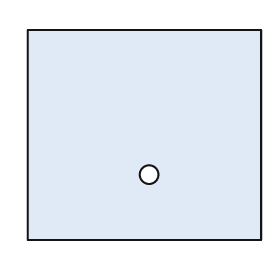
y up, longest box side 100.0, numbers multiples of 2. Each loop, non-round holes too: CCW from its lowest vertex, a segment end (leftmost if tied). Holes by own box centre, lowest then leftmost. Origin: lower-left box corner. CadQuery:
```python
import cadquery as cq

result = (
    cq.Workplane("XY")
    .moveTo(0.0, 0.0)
    .lineTo(100.0, 0.0)
    .lineTo(100.0, 90.0)
    .lineTo(0.0, 90.0)
    .close()
    .moveTo(52.0, 28.0)
    .circle(4.0)
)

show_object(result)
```